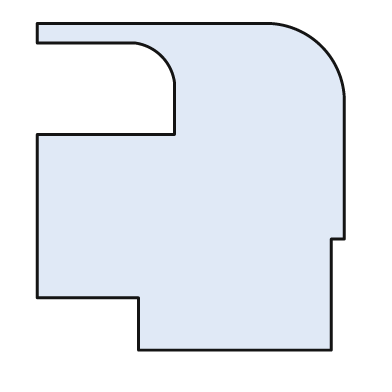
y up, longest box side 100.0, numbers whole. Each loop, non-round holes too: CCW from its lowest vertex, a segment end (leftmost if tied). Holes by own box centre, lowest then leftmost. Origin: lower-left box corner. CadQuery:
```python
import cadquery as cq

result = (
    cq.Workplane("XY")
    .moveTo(31.0, 0.0)
    .lineTo(90.0, 0.0)
    .lineTo(90.0, 34.0)
    .lineTo(94.0, 34.0)
    .lineTo(94.0, 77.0)
    .threePointArc((87.0, 93.0), (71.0, 100.0))
    .lineTo(0.0, 100.0)
    .lineTo(0.0, 94.0)
    .lineTo(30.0, 94.0)
    .threePointArc((38.0, 90.0), (42.0, 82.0))
    .lineTo(42.0, 66.0)
    .lineTo(0.0, 66.0)
    .lineTo(0.0, 16.0)
    .lineTo(31.0, 16.0)
    .close()
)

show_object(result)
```